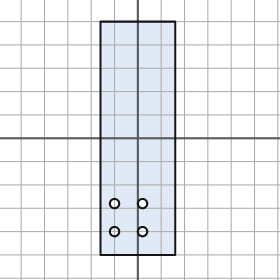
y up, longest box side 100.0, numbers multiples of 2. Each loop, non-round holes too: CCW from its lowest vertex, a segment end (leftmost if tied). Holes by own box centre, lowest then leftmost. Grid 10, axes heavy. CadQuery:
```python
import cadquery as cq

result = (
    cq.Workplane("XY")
    .moveTo(-16.0, -50.0)
    .lineTo(16.0, -50.0)
    .lineTo(16.0, 50.0)
    .lineTo(-16.0, 50.0)
    .close()
    .moveTo(-10.0, -40.0)
    .circle(2.0)
    .moveTo(2.0, -40.0)
    .circle(2.0)
    .moveTo(-10.0, -28.0)
    .circle(2.0)
    .moveTo(2.0, -28.0)
    .circle(2.0)
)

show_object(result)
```